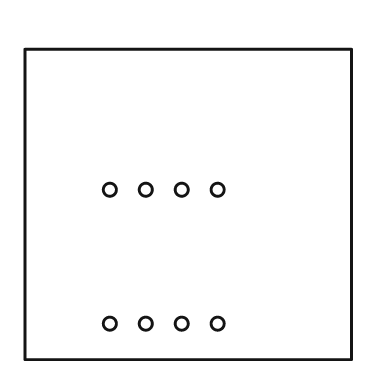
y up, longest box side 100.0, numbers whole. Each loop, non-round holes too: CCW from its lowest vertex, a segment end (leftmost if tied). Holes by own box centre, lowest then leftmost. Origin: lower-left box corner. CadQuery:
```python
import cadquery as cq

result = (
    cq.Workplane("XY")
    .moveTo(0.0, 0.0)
    .lineTo(100.0, 0.0)
    .lineTo(100.0, 95.0)
    .lineTo(0.0, 95.0)
    .close()
    .moveTo(26.0, 11.0)
    .circle(2.0)
    .moveTo(37.0, 11.0)
    .circle(2.0)
    .moveTo(48.0, 11.0)
    .circle(2.0)
    .moveTo(59.0, 11.0)
    .circle(2.0)
    .moveTo(26.0, 52.0)
    .circle(2.0)
    .moveTo(37.0, 52.0)
    .circle(2.0)
    .moveTo(48.0, 52.0)
    .circle(2.0)
    .moveTo(59.0, 52.0)
    .circle(2.0)
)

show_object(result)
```